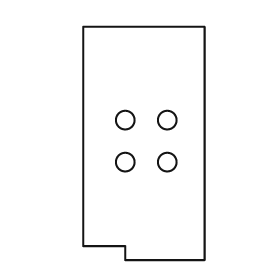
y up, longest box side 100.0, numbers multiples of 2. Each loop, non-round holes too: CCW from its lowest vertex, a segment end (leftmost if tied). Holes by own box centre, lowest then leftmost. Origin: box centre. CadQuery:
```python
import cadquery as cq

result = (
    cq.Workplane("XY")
    .moveTo(-8.0, -50.0)
    .lineTo(26.0, -50.0)
    .lineTo(26.0, 50.0)
    .lineTo(-26.0, 50.0)
    .lineTo(-26.0, -44.0)
    .lineTo(-8.0, -44.0)
    .close()
    .moveTo(-8.0, -8.0)
    .circle(4.0)
    .moveTo(10.0, -8.0)
    .circle(4.0)
    .moveTo(-8.0, 10.0)
    .circle(4.0)
    .moveTo(10.0, 10.0)
    .circle(4.0)
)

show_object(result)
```